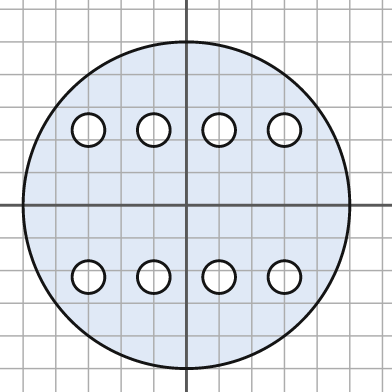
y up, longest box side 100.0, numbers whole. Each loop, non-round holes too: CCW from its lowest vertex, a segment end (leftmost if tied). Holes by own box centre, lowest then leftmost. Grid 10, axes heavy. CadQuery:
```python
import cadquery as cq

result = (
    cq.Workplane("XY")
    .moveTo(0.0, 0.0)
    .circle(50.0)
    .moveTo(-30.0, -22.0)
    .circle(5.0)
    .moveTo(-10.0, -22.0)
    .circle(5.0)
    .moveTo(10.0, -22.0)
    .circle(5.0)
    .moveTo(30.0, -22.0)
    .circle(5.0)
    .moveTo(-30.0, 23.0)
    .circle(5.0)
    .moveTo(-10.0, 23.0)
    .circle(5.0)
    .moveTo(10.0, 23.0)
    .circle(5.0)
    .moveTo(30.0, 23.0)
    .circle(5.0)
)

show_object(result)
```